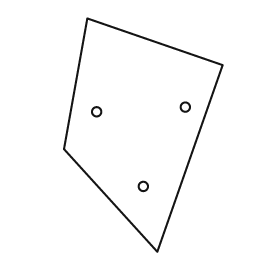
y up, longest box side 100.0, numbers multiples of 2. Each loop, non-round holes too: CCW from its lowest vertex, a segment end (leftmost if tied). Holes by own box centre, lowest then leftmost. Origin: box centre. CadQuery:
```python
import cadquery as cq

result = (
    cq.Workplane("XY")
    .moveTo(6.0, -50.0)
    .lineTo(34.0, 30.0)
    .lineTo(-24.0, 50.0)
    .lineTo(-34.0, -6.0)
    .close()
    .moveTo(0.0, -22.0)
    .circle(2.0)
    .moveTo(-20.0, 10.0)
    .circle(2.0)
    .moveTo(18.0, 12.0)
    .circle(2.0)
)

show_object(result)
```